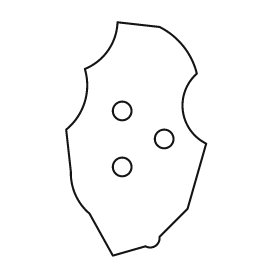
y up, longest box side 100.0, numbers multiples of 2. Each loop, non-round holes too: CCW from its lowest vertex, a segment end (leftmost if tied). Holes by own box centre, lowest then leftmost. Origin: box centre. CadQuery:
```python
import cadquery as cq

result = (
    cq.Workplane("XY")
    .moveTo(-10.0, -50.0)
    .lineTo(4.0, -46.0)
    .threePointArc((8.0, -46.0), (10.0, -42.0))
    .lineTo(22.0, -30.0)
    .lineTo(30.0, -2.0)
    .threePointArc((20.0, 12.0), (26.0, 28.0))
    .threePointArc((20.0, 40.0), (10.0, 48.0))
    .lineTo(-8.0, 50.0)
    .threePointArc((-12.0, 38.0), (-22.0, 30.0))
    .threePointArc((-22.0, 16.0), (-30.0, 4.0))
    .lineTo(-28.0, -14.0)
    .threePointArc((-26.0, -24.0), (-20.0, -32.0))
    .close()
    .moveTo(-6.0, -12.0)
    .circle(4.0)
    .moveTo(12.0, 0.0)
    .circle(4.0)
    .moveTo(-6.0, 12.0)
    .circle(4.0)
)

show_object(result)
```